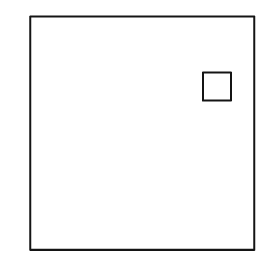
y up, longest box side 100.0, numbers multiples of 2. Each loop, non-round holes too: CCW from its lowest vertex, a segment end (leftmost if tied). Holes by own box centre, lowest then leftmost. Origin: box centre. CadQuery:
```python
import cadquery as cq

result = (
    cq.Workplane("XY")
    .moveTo(-48.0, -50.0)
    .lineTo(48.0, -50.0)
    .lineTo(48.0, 50.0)
    .lineTo(-48.0, 50.0)
    .close()
    .moveTo(26.0, 14.0)
    .lineTo(38.0, 14.0)
    .lineTo(38.0, 26.0)
    .lineTo(26.0, 26.0)
    .close()
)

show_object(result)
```